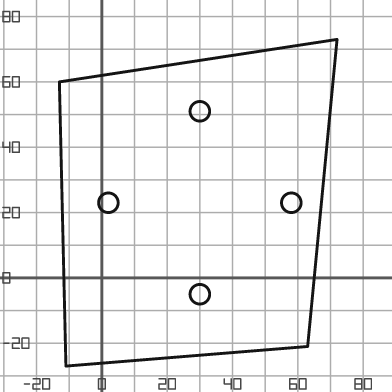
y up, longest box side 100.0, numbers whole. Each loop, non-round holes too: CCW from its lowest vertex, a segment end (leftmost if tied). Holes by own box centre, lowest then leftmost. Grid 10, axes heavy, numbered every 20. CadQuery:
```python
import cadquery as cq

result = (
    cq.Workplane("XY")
    .moveTo(-11.0, -27.0)
    .lineTo(63.0, -21.0)
    .lineTo(72.0, 73.0)
    .lineTo(-13.0, 60.0)
    .close()
    .moveTo(30.0, -5.0)
    .circle(3.0)
    .moveTo(2.0, 23.0)
    .circle(3.0)
    .moveTo(58.0, 23.0)
    .circle(3.0)
    .moveTo(30.0, 51.0)
    .circle(3.0)
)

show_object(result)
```